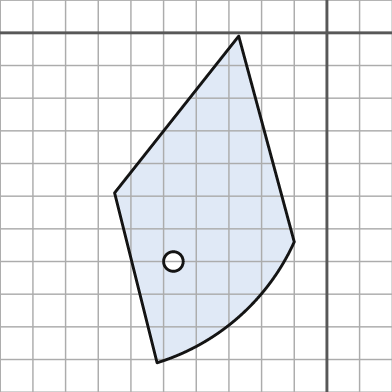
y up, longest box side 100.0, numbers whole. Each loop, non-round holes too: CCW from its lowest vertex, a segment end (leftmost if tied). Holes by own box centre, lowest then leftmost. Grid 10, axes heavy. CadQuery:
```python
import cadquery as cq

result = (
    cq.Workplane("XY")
    .moveTo(-52.0, -101.0)
    .threePointArc((-27.0, -87.0), (-10.0, -64.0))
    .lineTo(-27.0, -1.0)
    .lineTo(-65.0, -49.0)
    .close()
    .moveTo(-47.0, -70.0)
    .circle(3.0)
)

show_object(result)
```